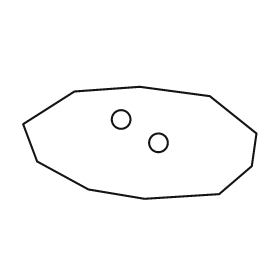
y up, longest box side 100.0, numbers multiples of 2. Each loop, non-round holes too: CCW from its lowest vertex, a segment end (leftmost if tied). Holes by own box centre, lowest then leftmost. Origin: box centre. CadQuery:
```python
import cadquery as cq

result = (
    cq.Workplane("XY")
    .moveTo(2.0, -24.0)
    .lineTo(34.0, -22.0)
    .lineTo(48.0, -10.0)
    .lineTo(50.0, 4.0)
    .lineTo(30.0, 20.0)
    .lineTo(0.0, 24.0)
    .lineTo(-28.0, 22.0)
    .lineTo(-50.0, 8.0)
    .lineTo(-44.0, -8.0)
    .lineTo(-22.0, -20.0)
    .close()
    .moveTo(8.0, 0.0)
    .circle(4.0)
    .moveTo(-8.0, 10.0)
    .circle(4.0)
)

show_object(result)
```